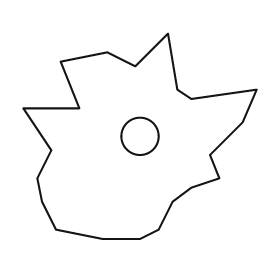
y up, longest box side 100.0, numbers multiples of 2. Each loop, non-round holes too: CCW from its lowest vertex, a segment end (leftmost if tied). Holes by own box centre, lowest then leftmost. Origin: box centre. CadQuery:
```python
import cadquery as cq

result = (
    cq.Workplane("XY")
    .moveTo(-16.0, -44.0)
    .lineTo(0.0, -44.0)
    .lineTo(8.0, -40.0)
    .lineTo(14.0, -28.0)
    .lineTo(22.0, -22.0)
    .lineTo(34.0, -18.0)
    .lineTo(30.0, -8.0)
    .lineTo(44.0, 6.0)
    .lineTo(50.0, 20.0)
    .lineTo(22.0, 16.0)
    .lineTo(16.0, 20.0)
    .lineTo(12.0, 44.0)
    .lineTo(-2.0, 30.0)
    .lineTo(-14.0, 36.0)
    .lineTo(-34.0, 32.0)
    .lineTo(-26.0, 12.0)
    .lineTo(-50.0, 12.0)
    .lineTo(-38.0, -6.0)
    .lineTo(-44.0, -18.0)
    .lineTo(-42.0, -28.0)
    .lineTo(-36.0, -40.0)
    .close()
    .moveTo(0.0, 0.0)
    .circle(8.0)
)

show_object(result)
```